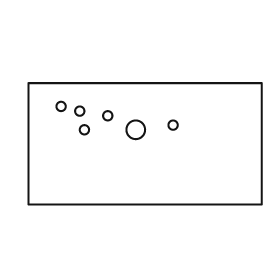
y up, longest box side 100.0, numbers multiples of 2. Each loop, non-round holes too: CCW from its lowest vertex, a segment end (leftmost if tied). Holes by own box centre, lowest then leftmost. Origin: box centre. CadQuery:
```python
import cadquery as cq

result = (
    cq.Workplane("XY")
    .moveTo(-50.0, -26.0)
    .lineTo(50.0, -26.0)
    .lineTo(50.0, 26.0)
    .lineTo(-50.0, 26.0)
    .close()
    .moveTo(-26.0, 6.0)
    .circle(2.0)
    .moveTo(-4.0, 6.0)
    .circle(4.0)
    .moveTo(12.0, 8.0)
    .circle(2.0)
    .moveTo(-16.0, 12.0)
    .circle(2.0)
    .moveTo(-28.0, 14.0)
    .circle(2.0)
    .moveTo(-36.0, 16.0)
    .circle(2.0)
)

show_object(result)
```